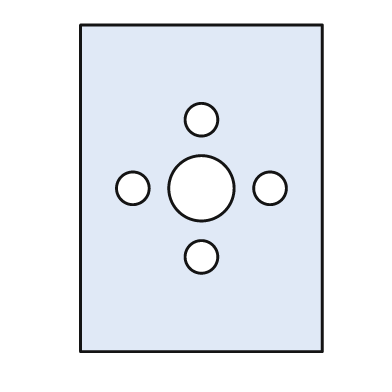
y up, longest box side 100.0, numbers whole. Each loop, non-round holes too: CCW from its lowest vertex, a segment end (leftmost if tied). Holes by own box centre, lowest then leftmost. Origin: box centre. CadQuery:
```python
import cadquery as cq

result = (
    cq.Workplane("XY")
    .moveTo(-37.0, -50.0)
    .lineTo(37.0, -50.0)
    .lineTo(37.0, 50.0)
    .lineTo(-37.0, 50.0)
    .close()
    .moveTo(0.0, -21.0)
    .circle(5.0)
    .moveTo(-21.0, 0.0)
    .circle(5.0)
    .moveTo(0.0, 0.0)
    .circle(10.0)
    .moveTo(21.0, 0.0)
    .circle(5.0)
    .moveTo(0.0, 21.0)
    .circle(5.0)
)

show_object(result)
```